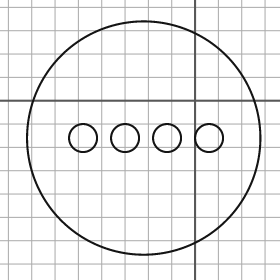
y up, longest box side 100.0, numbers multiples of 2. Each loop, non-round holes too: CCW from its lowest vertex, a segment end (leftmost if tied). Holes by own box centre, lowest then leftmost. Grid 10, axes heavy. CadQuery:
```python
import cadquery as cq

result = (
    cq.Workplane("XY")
    .moveTo(-22.0, -16.0)
    .circle(50.0)
    .moveTo(-48.0, -16.0)
    .circle(6.0)
    .moveTo(-30.0, -16.0)
    .circle(6.0)
    .moveTo(-12.0, -16.0)
    .circle(6.0)
    .moveTo(6.0, -16.0)
    .circle(6.0)
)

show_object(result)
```